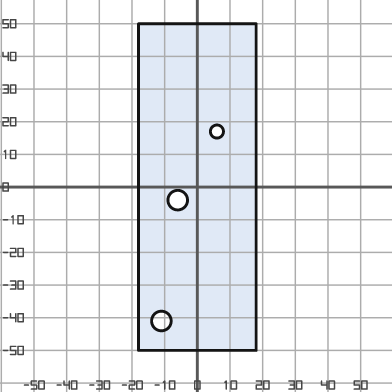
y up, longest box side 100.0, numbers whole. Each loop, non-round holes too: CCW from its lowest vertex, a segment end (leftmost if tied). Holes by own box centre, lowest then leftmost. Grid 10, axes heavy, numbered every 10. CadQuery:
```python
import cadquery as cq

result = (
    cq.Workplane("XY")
    .moveTo(-18.0, -50.0)
    .lineTo(18.0, -50.0)
    .lineTo(18.0, 50.0)
    .lineTo(-18.0, 50.0)
    .close()
    .moveTo(-11.0, -41.0)
    .circle(3.0)
    .moveTo(-6.0, -4.0)
    .circle(3.0)
    .moveTo(6.0, 17.0)
    .circle(2.0)
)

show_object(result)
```